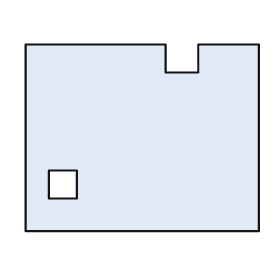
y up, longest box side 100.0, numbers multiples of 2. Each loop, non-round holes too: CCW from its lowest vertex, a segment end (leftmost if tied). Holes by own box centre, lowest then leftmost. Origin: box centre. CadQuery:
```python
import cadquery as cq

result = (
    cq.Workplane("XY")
    .moveTo(-50.0, -40.0)
    .lineTo(50.0, -40.0)
    .lineTo(50.0, 40.0)
    .lineTo(24.0, 40.0)
    .lineTo(24.0, 28.0)
    .lineTo(10.0, 28.0)
    .lineTo(10.0, 40.0)
    .lineTo(-50.0, 40.0)
    .close()
    .moveTo(-40.0, -26.0)
    .lineTo(-28.0, -26.0)
    .lineTo(-28.0, -14.0)
    .lineTo(-40.0, -14.0)
    .close()
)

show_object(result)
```